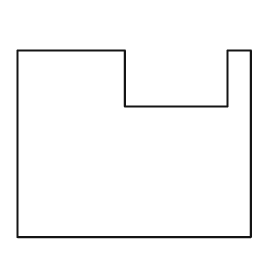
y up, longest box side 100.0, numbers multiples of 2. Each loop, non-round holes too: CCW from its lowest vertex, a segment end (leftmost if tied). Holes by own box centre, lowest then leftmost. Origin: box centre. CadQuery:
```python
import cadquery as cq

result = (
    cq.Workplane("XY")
    .moveTo(-50.0, -40.0)
    .lineTo(50.0, -40.0)
    .lineTo(50.0, 40.0)
    .lineTo(40.0, 40.0)
    .lineTo(40.0, 16.0)
    .lineTo(-4.0, 16.0)
    .lineTo(-4.0, 40.0)
    .lineTo(-50.0, 40.0)
    .close()
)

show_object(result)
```